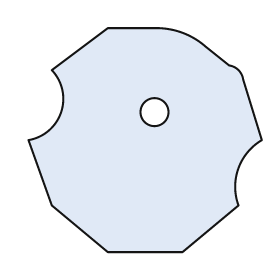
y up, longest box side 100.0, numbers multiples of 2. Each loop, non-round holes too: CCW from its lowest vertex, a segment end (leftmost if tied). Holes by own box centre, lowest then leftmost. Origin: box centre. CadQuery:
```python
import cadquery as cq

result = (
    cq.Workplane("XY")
    .moveTo(-16.0, -48.0)
    .lineTo(16.0, -48.0)
    .lineTo(40.0, -28.0)
    .threePointArc((40.0, -12.0), (50.0, 0.0))
    .lineTo(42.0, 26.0)
    .threePointArc((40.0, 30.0), (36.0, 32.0))
    .lineTo(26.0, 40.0)
    .threePointArc((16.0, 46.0), (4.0, 48.0))
    .lineTo(-16.0, 48.0)
    .lineTo(-40.0, 30.0)
    .threePointArc((-36.0, 12.0), (-50.0, 0.0))
    .lineTo(-40.0, -28.0)
    .close()
    .moveTo(4.0, 12.0)
    .circle(6.0)
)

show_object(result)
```